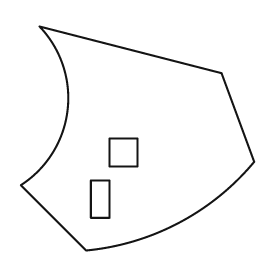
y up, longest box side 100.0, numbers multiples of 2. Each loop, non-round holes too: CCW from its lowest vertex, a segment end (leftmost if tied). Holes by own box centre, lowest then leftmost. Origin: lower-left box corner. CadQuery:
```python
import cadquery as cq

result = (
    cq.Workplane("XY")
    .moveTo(28.0, 0.0)
    .threePointArc((68.0, 12.0), (100.0, 38.0))
    .lineTo(86.0, 76.0)
    .lineTo(8.0, 96.0)
    .threePointArc((20.0, 60.0), (0.0, 28.0))
    .close()
    .moveTo(30.0, 14.0)
    .lineTo(38.0, 14.0)
    .lineTo(38.0, 30.0)
    .lineTo(30.0, 30.0)
    .close()
    .moveTo(38.0, 36.0)
    .lineTo(50.0, 36.0)
    .lineTo(50.0, 48.0)
    .lineTo(38.0, 48.0)
    .close()
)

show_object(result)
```